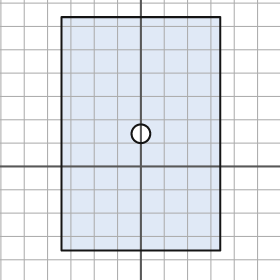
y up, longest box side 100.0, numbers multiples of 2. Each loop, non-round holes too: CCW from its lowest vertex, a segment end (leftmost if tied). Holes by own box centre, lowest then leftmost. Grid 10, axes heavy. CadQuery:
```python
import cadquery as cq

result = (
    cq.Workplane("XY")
    .moveTo(-34.0, -36.0)
    .lineTo(34.0, -36.0)
    .lineTo(34.0, 64.0)
    .lineTo(-34.0, 64.0)
    .close()
    .moveTo(0.0, 14.0)
    .circle(4.0)
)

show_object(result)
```